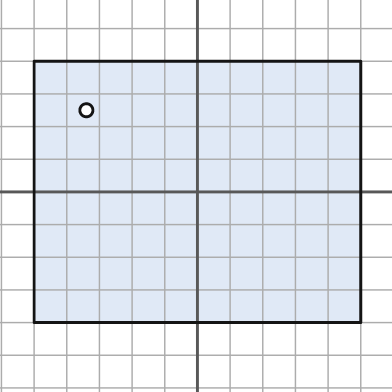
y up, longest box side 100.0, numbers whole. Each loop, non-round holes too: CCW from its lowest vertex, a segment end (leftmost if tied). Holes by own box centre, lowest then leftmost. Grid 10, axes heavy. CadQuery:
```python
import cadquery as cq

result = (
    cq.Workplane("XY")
    .moveTo(-50.0, -40.0)
    .lineTo(50.0, -40.0)
    .lineTo(50.0, 40.0)
    .lineTo(-50.0, 40.0)
    .close()
    .moveTo(-34.0, 25.0)
    .circle(2.0)
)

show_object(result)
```